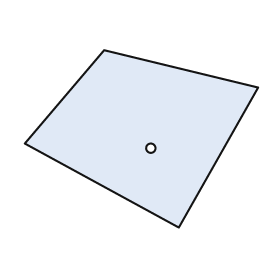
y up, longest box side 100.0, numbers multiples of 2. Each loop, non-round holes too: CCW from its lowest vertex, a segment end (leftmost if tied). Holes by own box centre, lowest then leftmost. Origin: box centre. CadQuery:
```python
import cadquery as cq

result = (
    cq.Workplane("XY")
    .moveTo(16.0, -38.0)
    .lineTo(50.0, 22.0)
    .lineTo(-16.0, 38.0)
    .lineTo(-50.0, -2.0)
    .close()
    .moveTo(4.0, -4.0)
    .circle(2.0)
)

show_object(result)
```